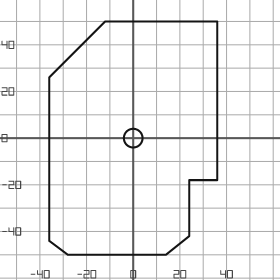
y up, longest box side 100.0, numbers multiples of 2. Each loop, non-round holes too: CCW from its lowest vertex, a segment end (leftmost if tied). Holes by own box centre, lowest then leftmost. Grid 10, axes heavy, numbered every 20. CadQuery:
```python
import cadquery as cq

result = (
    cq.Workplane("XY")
    .moveTo(-28.0, -50.0)
    .lineTo(14.0, -50.0)
    .lineTo(24.0, -42.0)
    .lineTo(24.0, -18.0)
    .lineTo(36.0, -18.0)
    .lineTo(36.0, 50.0)
    .lineTo(-12.0, 50.0)
    .lineTo(-36.0, 26.0)
    .lineTo(-36.0, -44.0)
    .close()
    .moveTo(0.0, 0.0)
    .circle(4.0)
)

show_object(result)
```